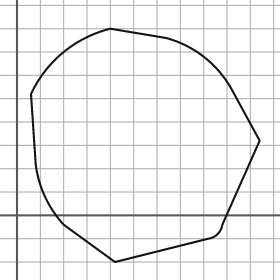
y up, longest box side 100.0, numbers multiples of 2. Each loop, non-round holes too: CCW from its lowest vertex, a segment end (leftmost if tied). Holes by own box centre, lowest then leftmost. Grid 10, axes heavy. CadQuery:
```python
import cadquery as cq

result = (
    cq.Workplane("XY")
    .moveTo(42.0, -20.0)
    .lineTo(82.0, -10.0)
    .threePointArc((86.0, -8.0), (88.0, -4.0))
    .lineTo(104.0, 32.0)
    .lineTo(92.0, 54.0)
    .threePointArc((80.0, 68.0), (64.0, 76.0))
    .lineTo(40.0, 80.0)
    .threePointArc((20.0, 70.0), (6.0, 52.0))
    .lineTo(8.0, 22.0)
    .threePointArc((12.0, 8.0), (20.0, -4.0))
    .close()
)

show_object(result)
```